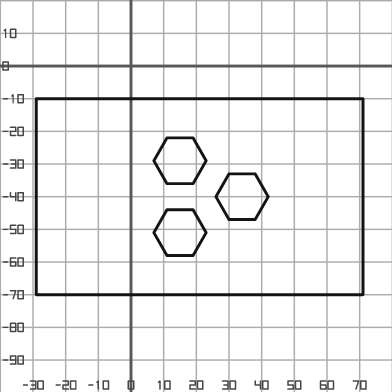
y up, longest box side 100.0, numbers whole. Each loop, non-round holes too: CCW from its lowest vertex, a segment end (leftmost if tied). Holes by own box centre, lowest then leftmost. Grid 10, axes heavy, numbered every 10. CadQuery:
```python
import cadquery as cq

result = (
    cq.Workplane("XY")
    .moveTo(-29.0, -70.0)
    .lineTo(71.0, -70.0)
    .lineTo(71.0, -10.0)
    .lineTo(-29.0, -10.0)
    .close()
    .moveTo(11.0, -58.0)
    .lineTo(19.0, -58.0)
    .lineTo(23.0, -51.0)
    .lineTo(19.0, -44.0)
    .lineTo(11.0, -44.0)
    .lineTo(7.0, -51.0)
    .close()
    .moveTo(30.0, -47.0)
    .lineTo(38.0, -47.0)
    .lineTo(42.0, -40.0)
    .lineTo(38.0, -33.0)
    .lineTo(30.0, -33.0)
    .lineTo(26.0, -40.0)
    .close()
    .moveTo(11.0, -36.0)
    .lineTo(19.0, -36.0)
    .lineTo(23.0, -29.0)
    .lineTo(19.0, -22.0)
    .lineTo(11.0, -22.0)
    .lineTo(7.0, -29.0)
    .close()
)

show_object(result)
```